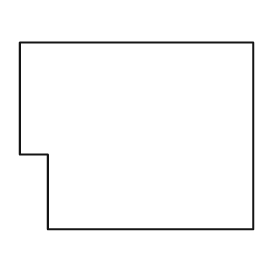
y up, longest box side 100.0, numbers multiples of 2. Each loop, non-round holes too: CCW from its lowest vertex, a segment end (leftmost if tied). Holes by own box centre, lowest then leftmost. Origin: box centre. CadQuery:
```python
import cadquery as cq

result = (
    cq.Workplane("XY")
    .moveTo(-38.0, -40.0)
    .lineTo(50.0, -40.0)
    .lineTo(50.0, 40.0)
    .lineTo(-50.0, 40.0)
    .lineTo(-50.0, -8.0)
    .lineTo(-38.0, -8.0)
    .close()
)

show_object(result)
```